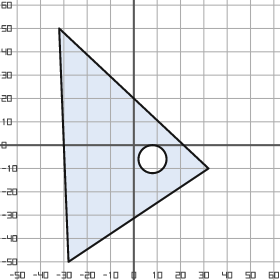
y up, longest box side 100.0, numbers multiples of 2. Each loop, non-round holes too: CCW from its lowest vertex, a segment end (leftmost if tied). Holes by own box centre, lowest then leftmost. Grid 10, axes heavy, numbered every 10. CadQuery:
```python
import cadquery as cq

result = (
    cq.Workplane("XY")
    .moveTo(-28.0, -50.0)
    .lineTo(32.0, -10.0)
    .lineTo(-32.0, 50.0)
    .close()
    .moveTo(8.0, -6.0)
    .circle(6.0)
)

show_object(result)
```